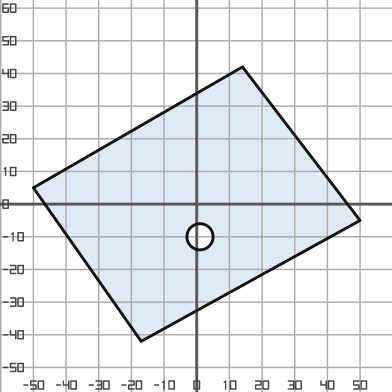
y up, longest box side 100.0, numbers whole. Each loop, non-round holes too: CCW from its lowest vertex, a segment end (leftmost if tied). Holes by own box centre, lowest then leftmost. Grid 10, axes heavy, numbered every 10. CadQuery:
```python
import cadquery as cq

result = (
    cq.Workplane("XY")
    .moveTo(-17.0, -42.0)
    .lineTo(50.0, -5.0)
    .lineTo(14.0, 42.0)
    .lineTo(-50.0, 5.0)
    .close()
    .moveTo(1.0, -10.0)
    .circle(4.0)
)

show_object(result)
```